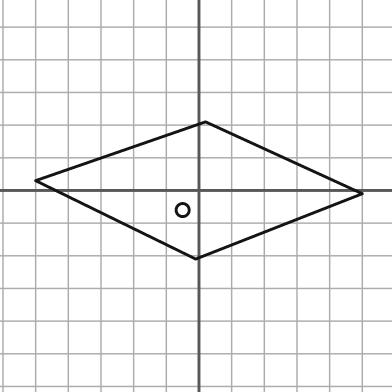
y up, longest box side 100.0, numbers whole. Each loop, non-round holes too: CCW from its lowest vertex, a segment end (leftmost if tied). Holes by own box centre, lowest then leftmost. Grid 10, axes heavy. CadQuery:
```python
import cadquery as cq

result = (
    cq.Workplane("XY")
    .moveTo(-1.0, -21.0)
    .lineTo(50.0, -1.0)
    .lineTo(2.0, 21.0)
    .lineTo(-50.0, 3.0)
    .close()
    .moveTo(-5.0, -6.0)
    .circle(2.0)
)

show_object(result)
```